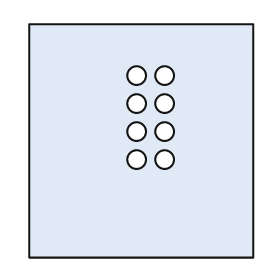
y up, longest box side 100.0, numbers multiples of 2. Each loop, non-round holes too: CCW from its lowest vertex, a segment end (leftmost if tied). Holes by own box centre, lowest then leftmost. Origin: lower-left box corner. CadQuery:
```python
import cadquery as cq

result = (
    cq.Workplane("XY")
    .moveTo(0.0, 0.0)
    .lineTo(96.0, 0.0)
    .lineTo(96.0, 100.0)
    .lineTo(0.0, 100.0)
    .close()
    .moveTo(46.0, 42.0)
    .circle(4.0)
    .moveTo(58.0, 42.0)
    .circle(4.0)
    .moveTo(46.0, 54.0)
    .circle(4.0)
    .moveTo(58.0, 54.0)
    .circle(4.0)
    .moveTo(46.0, 66.0)
    .circle(4.0)
    .moveTo(58.0, 66.0)
    .circle(4.0)
    .moveTo(46.0, 78.0)
    .circle(4.0)
    .moveTo(58.0, 78.0)
    .circle(4.0)
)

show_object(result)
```